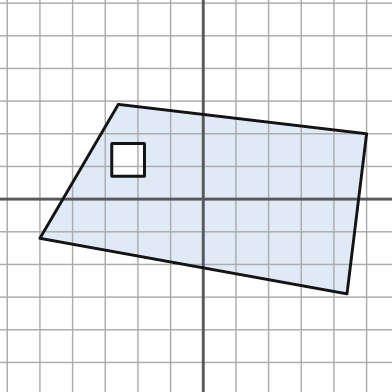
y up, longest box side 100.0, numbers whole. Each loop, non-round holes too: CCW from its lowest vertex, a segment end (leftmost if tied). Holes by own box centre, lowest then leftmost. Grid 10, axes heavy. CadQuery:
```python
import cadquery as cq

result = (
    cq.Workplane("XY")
    .moveTo(44.0, -29.0)
    .lineTo(50.0, 20.0)
    .lineTo(-26.0, 29.0)
    .lineTo(-50.0, -12.0)
    .close()
    .moveTo(-28.0, 7.0)
    .lineTo(-18.0, 7.0)
    .lineTo(-18.0, 17.0)
    .lineTo(-28.0, 17.0)
    .close()
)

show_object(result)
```